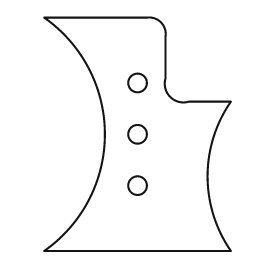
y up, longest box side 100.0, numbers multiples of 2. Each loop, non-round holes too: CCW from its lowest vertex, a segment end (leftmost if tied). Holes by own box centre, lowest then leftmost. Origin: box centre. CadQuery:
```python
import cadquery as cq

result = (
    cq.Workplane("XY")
    .moveTo(-40.0, -50.0)
    .lineTo(40.0, -50.0)
    .threePointArc((30.0, -18.0), (40.0, 14.0))
    .lineTo(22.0, 14.0)
    .threePointArc((14.0, 16.0), (12.0, 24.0))
    .lineTo(12.0, 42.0)
    .threePointArc((10.0, 48.0), (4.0, 50.0))
    .lineTo(-40.0, 50.0)
    .threePointArc((-14.0, 0.0), (-40.0, -50.0))
    .close()
    .moveTo(0.0, -22.0)
    .circle(4.0)
    .moveTo(0.0, 0.0)
    .circle(4.0)
    .moveTo(0.0, 22.0)
    .circle(4.0)
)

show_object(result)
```